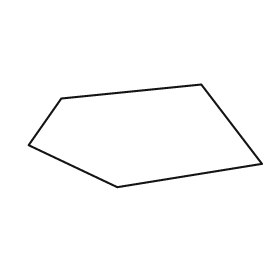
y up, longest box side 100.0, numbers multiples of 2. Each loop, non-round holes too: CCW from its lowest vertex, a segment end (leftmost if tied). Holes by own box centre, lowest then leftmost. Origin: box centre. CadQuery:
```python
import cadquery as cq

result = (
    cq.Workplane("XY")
    .moveTo(-12.0, -22.0)
    .lineTo(50.0, -12.0)
    .lineTo(24.0, 22.0)
    .lineTo(-36.0, 16.0)
    .lineTo(-50.0, -4.0)
    .close()
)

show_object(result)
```